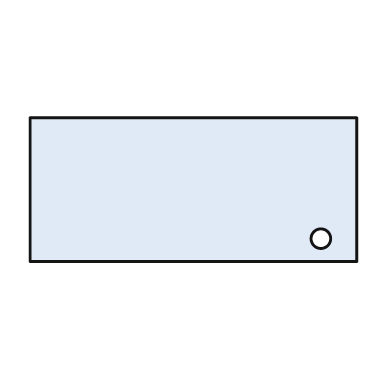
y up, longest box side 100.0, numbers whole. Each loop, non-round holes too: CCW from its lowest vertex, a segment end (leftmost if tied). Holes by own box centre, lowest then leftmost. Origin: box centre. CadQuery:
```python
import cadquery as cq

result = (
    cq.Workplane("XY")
    .moveTo(-50.0, -22.0)
    .lineTo(50.0, -22.0)
    .lineTo(50.0, 22.0)
    .lineTo(-50.0, 22.0)
    .close()
    .moveTo(39.0, -15.0)
    .circle(3.0)
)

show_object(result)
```